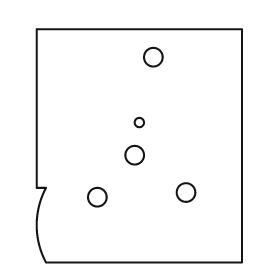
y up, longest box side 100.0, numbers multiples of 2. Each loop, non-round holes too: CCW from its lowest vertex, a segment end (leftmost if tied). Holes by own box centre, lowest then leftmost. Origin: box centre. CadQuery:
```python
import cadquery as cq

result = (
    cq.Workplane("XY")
    .moveTo(-40.0, -50.0)
    .lineTo(44.0, -50.0)
    .lineTo(44.0, 50.0)
    .lineTo(-44.0, 50.0)
    .lineTo(-44.0, -18.0)
    .lineTo(-40.0, -18.0)
    .threePointArc((-44.0, -34.0), (-40.0, -50.0))
    .close()
    .moveTo(-18.0, -22.0)
    .circle(4.0)
    .moveTo(20.0, -20.0)
    .circle(4.0)
    .moveTo(-2.0, -4.0)
    .circle(4.0)
    .moveTo(0.0, 10.0)
    .circle(2.0)
    .moveTo(6.0, 38.0)
    .circle(4.0)
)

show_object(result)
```